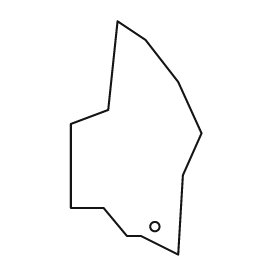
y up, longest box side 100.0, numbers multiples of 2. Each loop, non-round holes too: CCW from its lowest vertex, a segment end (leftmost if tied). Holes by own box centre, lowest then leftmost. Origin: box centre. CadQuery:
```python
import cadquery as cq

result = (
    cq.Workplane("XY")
    .moveTo(18.0, -50.0)
    .lineTo(20.0, -16.0)
    .lineTo(28.0, 2.0)
    .lineTo(18.0, 24.0)
    .lineTo(4.0, 42.0)
    .lineTo(-8.0, 50.0)
    .lineTo(-12.0, 12.0)
    .lineTo(-28.0, 6.0)
    .lineTo(-28.0, -30.0)
    .lineTo(-14.0, -30.0)
    .lineTo(-4.0, -42.0)
    .lineTo(2.0, -42.0)
    .close()
    .moveTo(8.0, -38.0)
    .circle(2.0)
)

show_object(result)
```